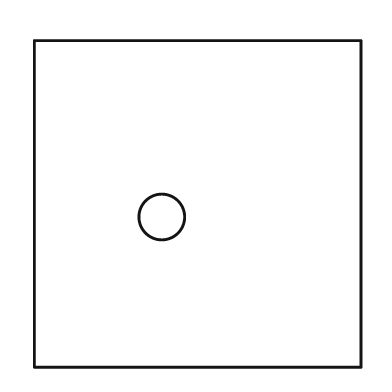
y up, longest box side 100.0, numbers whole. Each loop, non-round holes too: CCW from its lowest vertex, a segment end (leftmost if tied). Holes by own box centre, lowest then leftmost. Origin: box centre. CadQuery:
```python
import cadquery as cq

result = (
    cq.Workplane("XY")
    .moveTo(-50.0, -50.0)
    .lineTo(50.0, -50.0)
    .lineTo(50.0, 50.0)
    .lineTo(-50.0, 50.0)
    .close()
    .moveTo(-11.0, -4.0)
    .circle(7.0)
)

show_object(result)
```